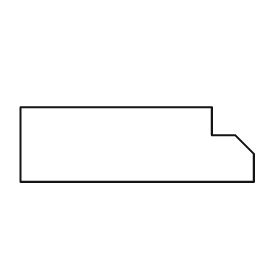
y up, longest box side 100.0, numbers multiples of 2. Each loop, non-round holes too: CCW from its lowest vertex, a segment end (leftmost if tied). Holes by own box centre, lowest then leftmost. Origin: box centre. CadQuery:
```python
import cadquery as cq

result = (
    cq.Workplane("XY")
    .moveTo(-50.0, -16.0)
    .lineTo(50.0, -16.0)
    .lineTo(50.0, -4.0)
    .lineTo(42.0, 4.0)
    .lineTo(32.0, 4.0)
    .lineTo(32.0, 16.0)
    .lineTo(-50.0, 16.0)
    .close()
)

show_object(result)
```